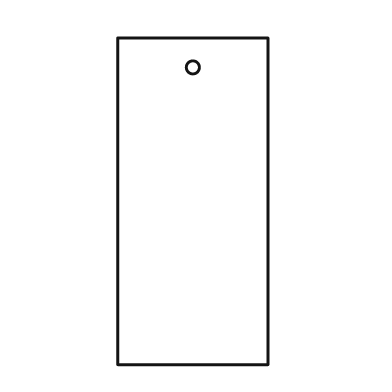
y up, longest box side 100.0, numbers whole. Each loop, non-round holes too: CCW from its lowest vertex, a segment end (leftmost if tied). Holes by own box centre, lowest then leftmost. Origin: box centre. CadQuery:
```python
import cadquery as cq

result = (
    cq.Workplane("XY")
    .moveTo(-23.0, -50.0)
    .lineTo(23.0, -50.0)
    .lineTo(23.0, 50.0)
    .lineTo(-23.0, 50.0)
    .close()
    .moveTo(0.0, 41.0)
    .circle(2.0)
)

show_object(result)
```